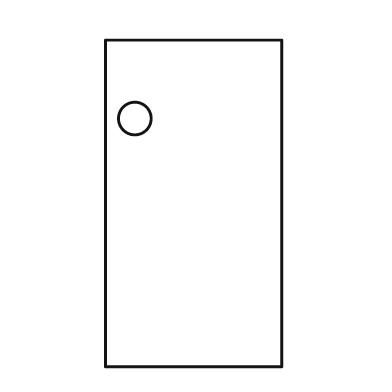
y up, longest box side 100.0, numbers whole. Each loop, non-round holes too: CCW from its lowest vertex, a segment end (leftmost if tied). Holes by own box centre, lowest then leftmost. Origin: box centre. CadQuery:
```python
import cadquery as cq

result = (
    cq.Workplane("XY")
    .moveTo(-27.0, -50.0)
    .lineTo(27.0, -50.0)
    .lineTo(27.0, 50.0)
    .lineTo(-27.0, 50.0)
    .close()
    .moveTo(-18.0, 26.0)
    .circle(5.0)
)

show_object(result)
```